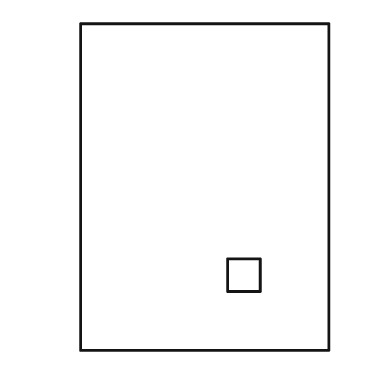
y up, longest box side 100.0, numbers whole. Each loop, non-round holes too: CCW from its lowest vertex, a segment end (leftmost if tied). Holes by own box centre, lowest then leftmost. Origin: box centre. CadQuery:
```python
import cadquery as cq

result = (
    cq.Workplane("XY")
    .moveTo(-38.0, -50.0)
    .lineTo(38.0, -50.0)
    .lineTo(38.0, 50.0)
    .lineTo(-38.0, 50.0)
    .close()
    .moveTo(7.0, -32.0)
    .lineTo(17.0, -32.0)
    .lineTo(17.0, -22.0)
    .lineTo(7.0, -22.0)
    .close()
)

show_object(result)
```